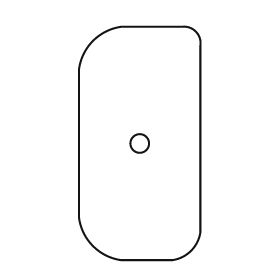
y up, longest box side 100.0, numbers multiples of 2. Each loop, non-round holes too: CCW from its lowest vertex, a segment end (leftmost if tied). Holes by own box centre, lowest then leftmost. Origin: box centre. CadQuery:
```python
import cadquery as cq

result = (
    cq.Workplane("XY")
    .moveTo(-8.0, -50.0)
    .lineTo(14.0, -50.0)
    .threePointArc((22.0, -46.0), (26.0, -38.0))
    .lineTo(26.0, 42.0)
    .threePointArc((24.0, 48.0), (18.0, 50.0))
    .lineTo(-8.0, 50.0)
    .threePointArc((-20.0, 44.0), (-26.0, 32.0))
    .lineTo(-26.0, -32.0)
    .threePointArc((-20.0, -44.0), (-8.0, -50.0))
    .close()
    .moveTo(0.0, 0.0)
    .circle(4.0)
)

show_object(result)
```